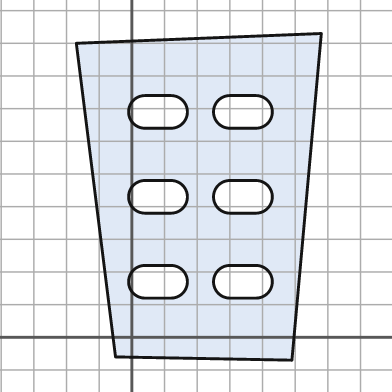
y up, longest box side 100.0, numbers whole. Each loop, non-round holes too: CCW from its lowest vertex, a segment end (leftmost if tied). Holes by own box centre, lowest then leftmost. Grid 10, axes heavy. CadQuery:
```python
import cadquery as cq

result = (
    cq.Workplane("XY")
    .moveTo(49.0, -7.0)
    .lineTo(58.0, 93.0)
    .lineTo(-17.0, 90.0)
    .lineTo(-5.0, -6.0)
    .close()
    .moveTo(4.0, 12.0)
    .lineTo(12.0, 12.0)
    .threePointArc((17.0, 17.0), (12.0, 22.0))
    .lineTo(4.0, 22.0)
    .threePointArc((-1.0, 17.0), (4.0, 12.0))
    .close()
    .moveTo(30.0, 12.0)
    .lineTo(38.0, 12.0)
    .threePointArc((43.0, 17.0), (38.0, 22.0))
    .lineTo(30.0, 22.0)
    .threePointArc((25.0, 17.0), (30.0, 12.0))
    .close()
    .moveTo(4.0, 38.0)
    .lineTo(12.0, 38.0)
    .threePointArc((17.0, 43.0), (12.0, 48.0))
    .lineTo(4.0, 48.0)
    .threePointArc((-1.0, 43.0), (4.0, 38.0))
    .close()
    .moveTo(30.0, 38.0)
    .lineTo(38.0, 38.0)
    .threePointArc((43.0, 43.0), (38.0, 48.0))
    .lineTo(30.0, 48.0)
    .threePointArc((25.0, 43.0), (30.0, 38.0))
    .close()
    .moveTo(4.0, 64.0)
    .lineTo(12.0, 64.0)
    .threePointArc((17.0, 69.0), (12.0, 74.0))
    .lineTo(4.0, 74.0)
    .threePointArc((-1.0, 69.0), (4.0, 64.0))
    .close()
    .moveTo(30.0, 64.0)
    .lineTo(38.0, 64.0)
    .threePointArc((43.0, 69.0), (38.0, 74.0))
    .lineTo(30.0, 74.0)
    .threePointArc((25.0, 69.0), (30.0, 64.0))
    .close()
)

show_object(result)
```